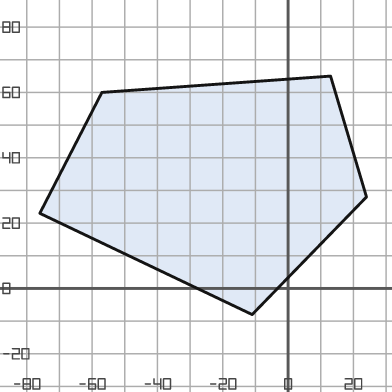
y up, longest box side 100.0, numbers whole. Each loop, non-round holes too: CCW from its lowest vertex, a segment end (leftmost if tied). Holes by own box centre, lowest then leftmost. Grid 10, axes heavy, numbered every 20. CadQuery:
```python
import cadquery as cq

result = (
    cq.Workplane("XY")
    .moveTo(-11.0, -8.0)
    .lineTo(24.0, 28.0)
    .lineTo(13.0, 65.0)
    .lineTo(-57.0, 60.0)
    .lineTo(-76.0, 23.0)
    .close()
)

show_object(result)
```